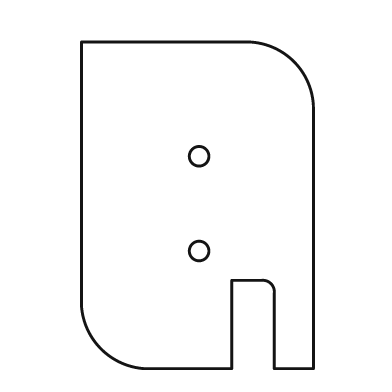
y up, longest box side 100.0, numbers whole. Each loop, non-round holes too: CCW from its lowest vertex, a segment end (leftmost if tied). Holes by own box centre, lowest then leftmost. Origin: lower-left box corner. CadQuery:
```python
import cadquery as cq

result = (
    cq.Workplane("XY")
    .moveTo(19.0, 0.0)
    .lineTo(46.0, 0.0)
    .lineTo(46.0, 27.0)
    .lineTo(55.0, 27.0)
    .threePointArc((58.0, 26.0), (59.0, 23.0))
    .lineTo(59.0, 0.0)
    .lineTo(71.0, 0.0)
    .lineTo(71.0, 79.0)
    .threePointArc((65.0, 94.0), (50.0, 100.0))
    .lineTo(0.0, 100.0)
    .lineTo(0.0, 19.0)
    .threePointArc((6.0, 6.0), (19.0, 0.0))
    .close()
    .moveTo(36.0, 36.0)
    .circle(3.0)
    .moveTo(36.0, 65.0)
    .circle(3.0)
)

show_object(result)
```